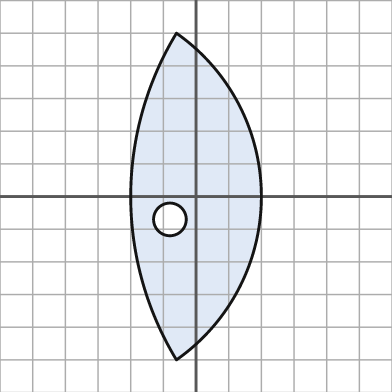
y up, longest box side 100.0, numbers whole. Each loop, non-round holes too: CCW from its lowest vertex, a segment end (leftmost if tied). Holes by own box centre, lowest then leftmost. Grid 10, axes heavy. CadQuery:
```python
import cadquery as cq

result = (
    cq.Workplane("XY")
    .moveTo(-6.0, -50.0)
    .threePointArc((20.0, 0.0), (-6.0, 50.0))
    .threePointArc((-20.0, 0.0), (-6.0, -50.0))
    .close()
    .moveTo(-8.0, -7.0)
    .circle(5.0)
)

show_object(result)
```